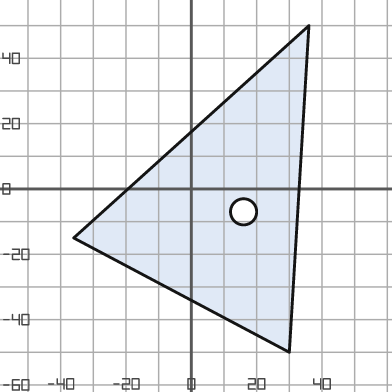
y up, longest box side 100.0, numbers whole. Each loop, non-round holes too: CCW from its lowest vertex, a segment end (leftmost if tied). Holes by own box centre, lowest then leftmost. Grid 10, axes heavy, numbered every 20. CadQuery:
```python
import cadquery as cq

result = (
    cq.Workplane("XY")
    .moveTo(30.0, -50.0)
    .lineTo(36.0, 50.0)
    .lineTo(-36.0, -15.0)
    .close()
    .moveTo(16.0, -7.0)
    .circle(4.0)
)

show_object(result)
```